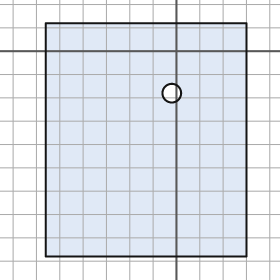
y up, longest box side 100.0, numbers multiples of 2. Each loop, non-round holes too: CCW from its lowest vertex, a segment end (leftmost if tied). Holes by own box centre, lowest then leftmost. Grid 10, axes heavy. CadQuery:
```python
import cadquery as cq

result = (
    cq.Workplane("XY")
    .moveTo(-56.0, -88.0)
    .lineTo(30.0, -88.0)
    .lineTo(30.0, 12.0)
    .lineTo(-56.0, 12.0)
    .close()
    .moveTo(-2.0, -18.0)
    .circle(4.0)
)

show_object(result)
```